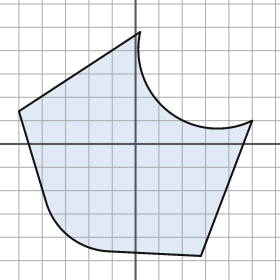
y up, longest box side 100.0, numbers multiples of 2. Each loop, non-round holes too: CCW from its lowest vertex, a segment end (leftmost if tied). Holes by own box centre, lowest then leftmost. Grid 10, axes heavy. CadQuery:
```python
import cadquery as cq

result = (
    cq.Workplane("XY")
    .moveTo(28.0, -48.0)
    .lineTo(50.0, 10.0)
    .threePointArc((14.0, 14.0), (2.0, 48.0))
    .lineTo(-50.0, 14.0)
    .lineTo(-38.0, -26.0)
    .threePointArc((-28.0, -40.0), (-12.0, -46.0))
    .close()
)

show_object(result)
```